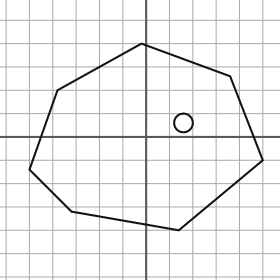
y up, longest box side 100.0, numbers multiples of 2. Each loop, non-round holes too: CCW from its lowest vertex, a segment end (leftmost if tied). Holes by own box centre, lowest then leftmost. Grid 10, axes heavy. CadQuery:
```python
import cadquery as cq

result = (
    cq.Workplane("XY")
    .moveTo(14.0, -40.0)
    .lineTo(50.0, -10.0)
    .lineTo(36.0, 26.0)
    .lineTo(-2.0, 40.0)
    .lineTo(-38.0, 20.0)
    .lineTo(-50.0, -14.0)
    .lineTo(-32.0, -32.0)
    .close()
    .moveTo(16.0, 6.0)
    .circle(4.0)
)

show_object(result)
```